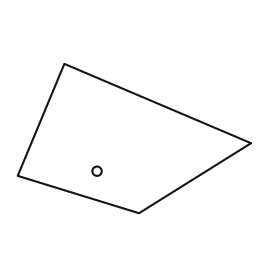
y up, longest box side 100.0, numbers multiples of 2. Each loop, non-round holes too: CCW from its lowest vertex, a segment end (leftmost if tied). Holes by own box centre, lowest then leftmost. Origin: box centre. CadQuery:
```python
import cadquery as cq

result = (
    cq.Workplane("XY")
    .moveTo(2.0, -32.0)
    .lineTo(50.0, -2.0)
    .lineTo(-30.0, 32.0)
    .lineTo(-50.0, -16.0)
    .close()
    .moveTo(-16.0, -14.0)
    .circle(2.0)
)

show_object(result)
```